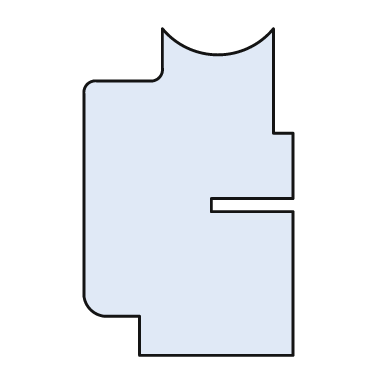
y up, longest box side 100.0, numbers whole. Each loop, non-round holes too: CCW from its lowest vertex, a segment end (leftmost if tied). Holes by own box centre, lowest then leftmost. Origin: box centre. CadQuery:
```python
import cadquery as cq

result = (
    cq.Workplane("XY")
    .moveTo(-15.0, -50.0)
    .lineTo(32.0, -50.0)
    .lineTo(32.0, -6.0)
    .lineTo(7.0, -6.0)
    .lineTo(7.0, -2.0)
    .lineTo(32.0, -2.0)
    .lineTo(32.0, 18.0)
    .lineTo(26.0, 18.0)
    .lineTo(26.0, 50.0)
    .threePointArc((9.0, 42.0), (-8.0, 50.0))
    .lineTo(-8.0, 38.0)
    .threePointArc((-9.0, 35.0), (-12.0, 34.0))
    .lineTo(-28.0, 34.0)
    .threePointArc((-31.0, 33.0), (-32.0, 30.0))
    .lineTo(-32.0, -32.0)
    .threePointArc((-30.0, -36.0), (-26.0, -38.0))
    .lineTo(-15.0, -38.0)
    .close()
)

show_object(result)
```